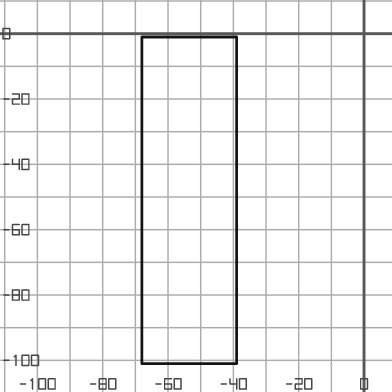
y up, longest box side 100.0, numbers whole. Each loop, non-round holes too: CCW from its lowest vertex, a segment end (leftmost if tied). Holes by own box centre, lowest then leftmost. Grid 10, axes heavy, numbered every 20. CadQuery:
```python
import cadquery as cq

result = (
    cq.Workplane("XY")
    .moveTo(-68.0, -101.0)
    .lineTo(-39.0, -101.0)
    .lineTo(-39.0, -1.0)
    .lineTo(-68.0, -1.0)
    .close()
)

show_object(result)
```